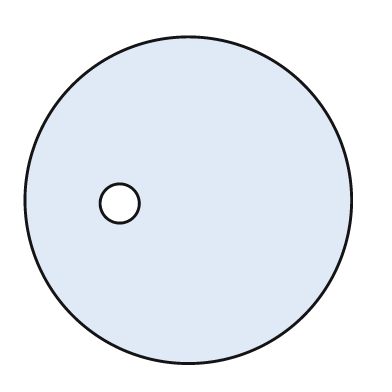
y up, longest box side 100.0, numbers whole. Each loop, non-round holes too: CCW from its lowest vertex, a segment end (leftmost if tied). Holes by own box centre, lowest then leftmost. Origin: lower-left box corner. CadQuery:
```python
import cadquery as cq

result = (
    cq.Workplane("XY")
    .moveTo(50.0, 50.0)
    .circle(50.0)
    .moveTo(29.0, 49.0)
    .circle(6.0)
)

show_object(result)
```